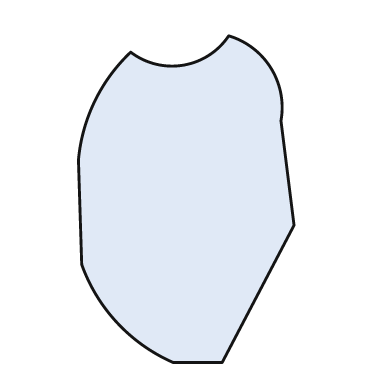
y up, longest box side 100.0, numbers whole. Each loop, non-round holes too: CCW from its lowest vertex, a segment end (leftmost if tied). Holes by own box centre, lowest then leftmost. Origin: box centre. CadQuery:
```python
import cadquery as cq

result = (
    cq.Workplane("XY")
    .moveTo(-4.0, -50.0)
    .lineTo(11.0, -50.0)
    .lineTo(33.0, -8.0)
    .lineTo(29.0, 24.0)
    .threePointArc((26.0, 40.0), (13.0, 50.0))
    .threePointArc((-1.0, 41.0), (-17.0, 45.0))
    .threePointArc((-28.0, 30.0), (-33.0, 12.0))
    .lineTo(-32.0, -20.0)
    .threePointArc((-21.0, -38.0), (-4.0, -50.0))
    .close()
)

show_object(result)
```